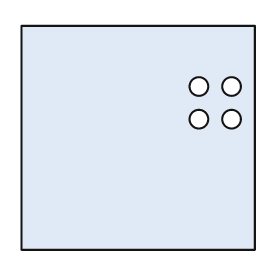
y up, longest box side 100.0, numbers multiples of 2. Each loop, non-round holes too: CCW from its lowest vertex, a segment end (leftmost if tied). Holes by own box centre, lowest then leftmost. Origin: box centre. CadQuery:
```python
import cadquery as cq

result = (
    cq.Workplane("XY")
    .moveTo(-50.0, -48.0)
    .lineTo(50.0, -48.0)
    .lineTo(50.0, 48.0)
    .lineTo(-50.0, 48.0)
    .close()
    .moveTo(26.0, 8.0)
    .circle(4.0)
    .moveTo(40.0, 8.0)
    .circle(4.0)
    .moveTo(26.0, 22.0)
    .circle(4.0)
    .moveTo(40.0, 22.0)
    .circle(4.0)
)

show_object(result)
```